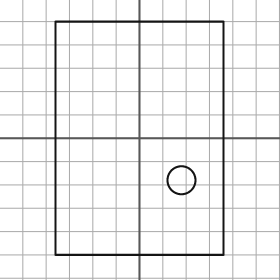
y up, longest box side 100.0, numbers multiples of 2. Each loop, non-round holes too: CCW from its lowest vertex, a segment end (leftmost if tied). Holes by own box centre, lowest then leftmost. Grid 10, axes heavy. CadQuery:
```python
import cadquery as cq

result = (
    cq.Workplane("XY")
    .moveTo(-36.0, -50.0)
    .lineTo(36.0, -50.0)
    .lineTo(36.0, 50.0)
    .lineTo(-36.0, 50.0)
    .close()
    .moveTo(18.0, -18.0)
    .circle(6.0)
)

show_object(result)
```